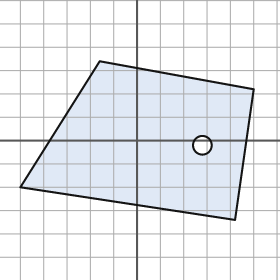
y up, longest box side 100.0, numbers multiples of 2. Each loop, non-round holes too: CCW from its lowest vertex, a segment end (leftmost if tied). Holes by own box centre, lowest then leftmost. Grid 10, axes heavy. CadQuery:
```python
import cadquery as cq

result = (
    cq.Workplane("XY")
    .moveTo(42.0, -34.0)
    .lineTo(50.0, 22.0)
    .lineTo(-16.0, 34.0)
    .lineTo(-50.0, -20.0)
    .close()
    .moveTo(28.0, -2.0)
    .circle(4.0)
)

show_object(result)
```